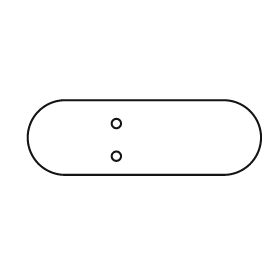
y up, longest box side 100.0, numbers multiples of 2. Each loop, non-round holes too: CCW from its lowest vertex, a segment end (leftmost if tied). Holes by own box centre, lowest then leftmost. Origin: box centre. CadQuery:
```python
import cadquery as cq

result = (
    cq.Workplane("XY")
    .moveTo(-34.0, -16.0)
    .lineTo(34.0, -16.0)
    .threePointArc((50.0, 0.0), (34.0, 16.0))
    .lineTo(-34.0, 16.0)
    .threePointArc((-50.0, 0.0), (-34.0, -16.0))
    .close()
    .moveTo(-12.0, -8.0)
    .circle(2.0)
    .moveTo(-12.0, 6.0)
    .circle(2.0)
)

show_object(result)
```